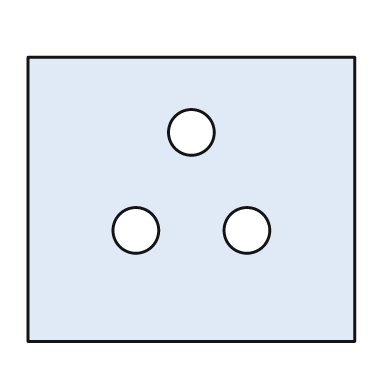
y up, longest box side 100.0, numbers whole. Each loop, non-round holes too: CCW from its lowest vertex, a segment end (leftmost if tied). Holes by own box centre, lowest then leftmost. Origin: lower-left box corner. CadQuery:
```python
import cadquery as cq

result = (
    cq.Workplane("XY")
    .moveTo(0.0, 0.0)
    .lineTo(100.0, 0.0)
    .lineTo(100.0, 87.0)
    .lineTo(0.0, 87.0)
    .close()
    .moveTo(33.0, 34.0)
    .circle(7.0)
    .moveTo(67.0, 34.0)
    .circle(7.0)
    .moveTo(50.0, 64.0)
    .circle(7.0)
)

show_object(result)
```